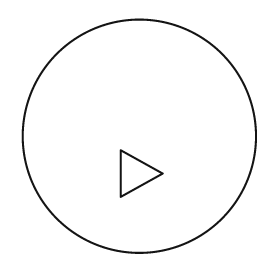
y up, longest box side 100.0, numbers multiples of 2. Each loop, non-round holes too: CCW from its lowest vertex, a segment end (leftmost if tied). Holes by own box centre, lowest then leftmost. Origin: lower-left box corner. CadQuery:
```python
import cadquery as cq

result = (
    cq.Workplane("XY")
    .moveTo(50.0, 50.0)
    .circle(50.0)
    .moveTo(42.0, 24.0)
    .lineTo(60.0, 34.0)
    .lineTo(42.0, 44.0)
    .close()
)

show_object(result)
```